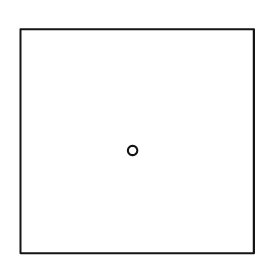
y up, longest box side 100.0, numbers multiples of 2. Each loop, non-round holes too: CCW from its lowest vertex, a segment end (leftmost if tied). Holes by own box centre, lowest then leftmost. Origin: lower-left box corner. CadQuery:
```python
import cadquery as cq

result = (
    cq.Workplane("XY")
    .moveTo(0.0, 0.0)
    .lineTo(100.0, 0.0)
    .lineTo(100.0, 96.0)
    .lineTo(0.0, 96.0)
    .close()
    .moveTo(48.0, 44.0)
    .circle(2.0)
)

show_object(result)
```